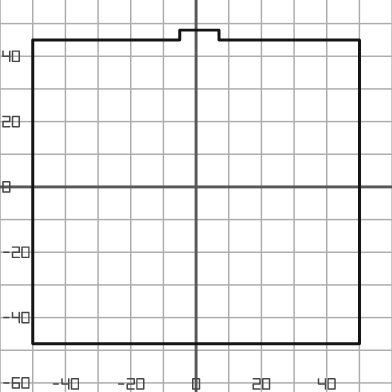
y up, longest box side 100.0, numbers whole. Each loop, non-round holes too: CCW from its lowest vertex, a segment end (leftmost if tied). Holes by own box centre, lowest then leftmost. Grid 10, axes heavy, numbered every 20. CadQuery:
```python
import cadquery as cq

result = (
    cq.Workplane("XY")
    .moveTo(-50.0, -48.0)
    .lineTo(50.0, -48.0)
    .lineTo(50.0, 45.0)
    .lineTo(7.0, 45.0)
    .lineTo(7.0, 48.0)
    .lineTo(-5.0, 48.0)
    .lineTo(-5.0, 45.0)
    .lineTo(-50.0, 45.0)
    .close()
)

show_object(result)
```